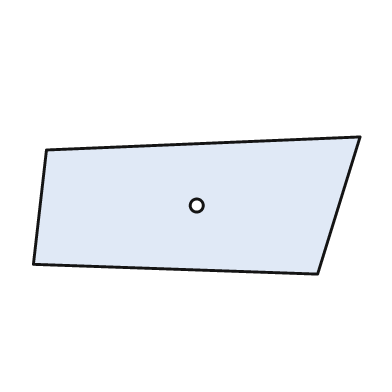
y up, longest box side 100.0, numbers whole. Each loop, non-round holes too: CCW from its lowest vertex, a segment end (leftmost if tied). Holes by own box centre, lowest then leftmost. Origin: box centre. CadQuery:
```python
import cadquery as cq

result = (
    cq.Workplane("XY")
    .moveTo(37.0, -21.0)
    .lineTo(50.0, 21.0)
    .lineTo(-46.0, 17.0)
    .lineTo(-50.0, -18.0)
    .close()
    .moveTo(0.0, 0.0)
    .circle(2.0)
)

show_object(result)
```